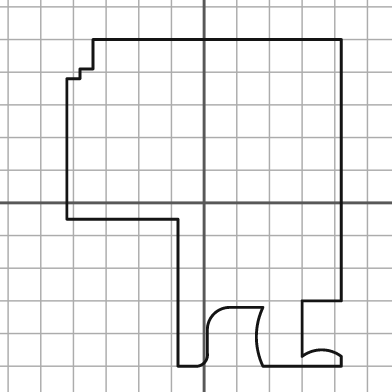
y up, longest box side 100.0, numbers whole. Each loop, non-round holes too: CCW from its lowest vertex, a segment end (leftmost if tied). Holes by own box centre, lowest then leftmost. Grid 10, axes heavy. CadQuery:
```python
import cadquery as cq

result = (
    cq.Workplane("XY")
    .moveTo(-8.0, -50.0)
    .lineTo(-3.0, -50.0)
    .threePointArc((0.0, -49.0), (1.0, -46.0))
    .lineTo(1.0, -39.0)
    .threePointArc((3.0, -34.0), (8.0, -32.0))
    .lineTo(18.0, -32.0)
    .threePointArc((16.0, -41.0), (18.0, -50.0))
    .lineTo(42.0, -50.0)
    .lineTo(42.0, -47.0)
    .threePointArc((36.0, -45.0), (30.0, -47.0))
    .lineTo(30.0, -30.0)
    .lineTo(42.0, -30.0)
    .lineTo(42.0, 50.0)
    .lineTo(-34.0, 50.0)
    .lineTo(-34.0, 41.0)
    .lineTo(-38.0, 41.0)
    .lineTo(-38.0, 38.0)
    .lineTo(-42.0, 38.0)
    .lineTo(-42.0, -5.0)
    .lineTo(-8.0, -5.0)
    .close()
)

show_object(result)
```